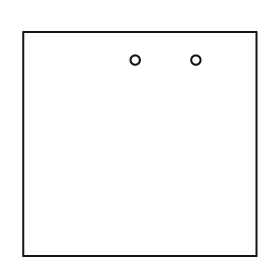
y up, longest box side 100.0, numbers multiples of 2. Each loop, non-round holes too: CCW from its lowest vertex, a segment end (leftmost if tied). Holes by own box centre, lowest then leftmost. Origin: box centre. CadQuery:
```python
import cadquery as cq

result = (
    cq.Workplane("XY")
    .moveTo(-50.0, -48.0)
    .lineTo(50.0, -48.0)
    .lineTo(50.0, 48.0)
    .lineTo(-50.0, 48.0)
    .close()
    .moveTo(-2.0, 36.0)
    .circle(2.0)
    .moveTo(24.0, 36.0)
    .circle(2.0)
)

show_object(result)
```